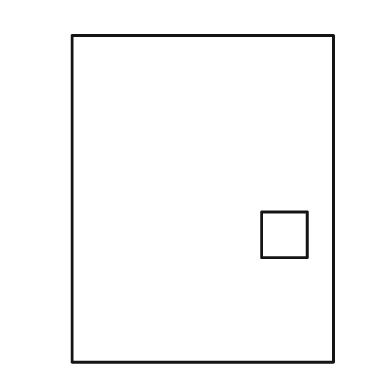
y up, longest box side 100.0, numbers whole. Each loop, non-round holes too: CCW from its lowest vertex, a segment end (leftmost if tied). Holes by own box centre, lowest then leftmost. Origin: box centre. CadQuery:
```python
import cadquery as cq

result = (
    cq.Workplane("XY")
    .moveTo(-40.0, -50.0)
    .lineTo(40.0, -50.0)
    .lineTo(40.0, 50.0)
    .lineTo(-40.0, 50.0)
    .close()
    .moveTo(18.0, -18.0)
    .lineTo(32.0, -18.0)
    .lineTo(32.0, -4.0)
    .lineTo(18.0, -4.0)
    .close()
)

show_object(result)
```